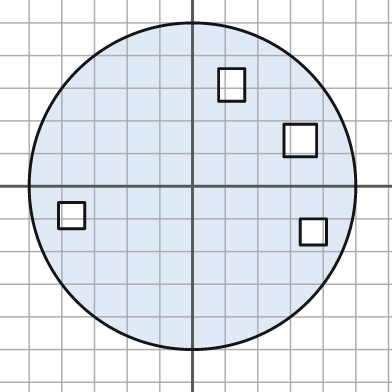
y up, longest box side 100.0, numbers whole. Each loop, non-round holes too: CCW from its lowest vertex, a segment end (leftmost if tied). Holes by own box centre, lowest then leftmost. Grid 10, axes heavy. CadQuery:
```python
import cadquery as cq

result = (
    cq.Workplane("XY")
    .moveTo(0.0, 0.0)
    .circle(50.0)
    .moveTo(33.0, -18.0)
    .lineTo(41.0, -18.0)
    .lineTo(41.0, -10.0)
    .lineTo(33.0, -10.0)
    .close()
    .moveTo(-41.0, -13.0)
    .lineTo(-33.0, -13.0)
    .lineTo(-33.0, -5.0)
    .lineTo(-41.0, -5.0)
    .close()
    .moveTo(28.0, 9.0)
    .lineTo(38.0, 9.0)
    .lineTo(38.0, 19.0)
    .lineTo(28.0, 19.0)
    .close()
    .moveTo(8.0, 26.0)
    .lineTo(16.0, 26.0)
    .lineTo(16.0, 36.0)
    .lineTo(8.0, 36.0)
    .close()
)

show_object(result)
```